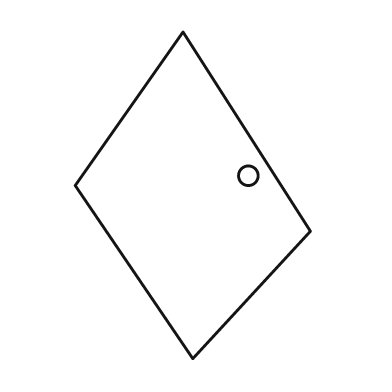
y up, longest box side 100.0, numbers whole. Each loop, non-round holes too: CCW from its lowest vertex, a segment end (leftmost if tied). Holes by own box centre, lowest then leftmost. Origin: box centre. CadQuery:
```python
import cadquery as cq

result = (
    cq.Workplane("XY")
    .moveTo(0.0, -50.0)
    .lineTo(36.0, -11.0)
    .lineTo(-3.0, 50.0)
    .lineTo(-36.0, 3.0)
    .close()
    .moveTo(17.0, 6.0)
    .circle(3.0)
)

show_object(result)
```